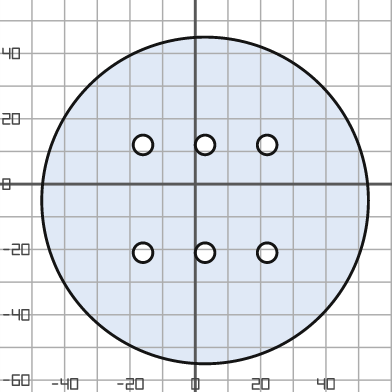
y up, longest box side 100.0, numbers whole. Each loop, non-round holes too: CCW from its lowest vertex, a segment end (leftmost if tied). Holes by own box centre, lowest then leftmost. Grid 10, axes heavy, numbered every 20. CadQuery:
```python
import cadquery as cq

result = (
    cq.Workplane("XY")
    .moveTo(3.0, -5.0)
    .circle(50.0)
    .moveTo(-16.0, -21.0)
    .circle(3.0)
    .moveTo(3.0, -21.0)
    .circle(3.0)
    .moveTo(22.0, -21.0)
    .circle(3.0)
    .moveTo(-16.0, 12.0)
    .circle(3.0)
    .moveTo(3.0, 12.0)
    .circle(3.0)
    .moveTo(22.0, 12.0)
    .circle(3.0)
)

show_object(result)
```